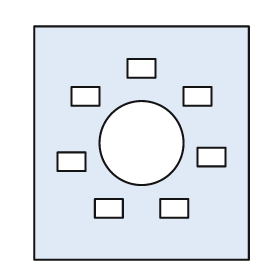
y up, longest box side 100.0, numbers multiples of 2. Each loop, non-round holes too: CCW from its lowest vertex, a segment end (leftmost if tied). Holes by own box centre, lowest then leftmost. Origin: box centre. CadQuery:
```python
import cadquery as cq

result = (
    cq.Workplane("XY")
    .moveTo(-46.0, -50.0)
    .lineTo(46.0, -50.0)
    .lineTo(46.0, 50.0)
    .lineTo(-46.0, 50.0)
    .close()
    .moveTo(-20.0, -32.0)
    .lineTo(-8.0, -32.0)
    .lineTo(-8.0, -24.0)
    .lineTo(-20.0, -24.0)
    .close()
    .moveTo(8.0, -32.0)
    .lineTo(20.0, -32.0)
    .lineTo(20.0, -24.0)
    .lineTo(8.0, -24.0)
    .close()
    .moveTo(-36.0, -12.0)
    .lineTo(-24.0, -12.0)
    .lineTo(-24.0, -4.0)
    .lineTo(-36.0, -4.0)
    .close()
    .moveTo(24.0, -10.0)
    .lineTo(36.0, -10.0)
    .lineTo(36.0, -2.0)
    .lineTo(24.0, -2.0)
    .close()
    .moveTo(0.0, 0.0)
    .circle(18.0)
    .moveTo(-30.0, 16.0)
    .lineTo(-18.0, 16.0)
    .lineTo(-18.0, 24.0)
    .lineTo(-30.0, 24.0)
    .close()
    .moveTo(18.0, 16.0)
    .lineTo(30.0, 16.0)
    .lineTo(30.0, 24.0)
    .lineTo(18.0, 24.0)
    .close()
    .moveTo(-6.0, 28.0)
    .lineTo(6.0, 28.0)
    .lineTo(6.0, 36.0)
    .lineTo(-6.0, 36.0)
    .close()
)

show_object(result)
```